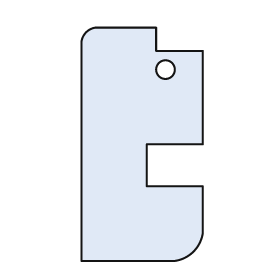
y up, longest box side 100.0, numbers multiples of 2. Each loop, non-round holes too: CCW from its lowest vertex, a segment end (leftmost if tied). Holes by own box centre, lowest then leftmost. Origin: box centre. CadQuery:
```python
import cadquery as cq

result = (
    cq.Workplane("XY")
    .moveTo(-26.0, -50.0)
    .lineTo(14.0, -50.0)
    .threePointArc((22.0, -46.0), (26.0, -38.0))
    .lineTo(26.0, -18.0)
    .lineTo(2.0, -18.0)
    .lineTo(2.0, 0.0)
    .lineTo(26.0, 0.0)
    .lineTo(26.0, 40.0)
    .lineTo(6.0, 40.0)
    .lineTo(6.0, 50.0)
    .lineTo(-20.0, 50.0)
    .threePointArc((-24.0, 48.0), (-26.0, 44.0))
    .close()
    .moveTo(10.0, 32.0)
    .circle(4.0)
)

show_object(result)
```